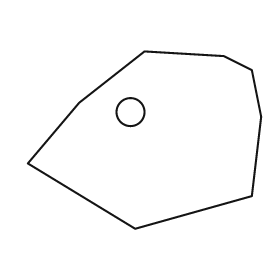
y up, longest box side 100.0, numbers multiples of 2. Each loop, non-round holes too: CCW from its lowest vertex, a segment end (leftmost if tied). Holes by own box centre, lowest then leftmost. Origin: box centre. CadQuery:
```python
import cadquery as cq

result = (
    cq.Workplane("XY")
    .moveTo(-4.0, -38.0)
    .lineTo(46.0, -24.0)
    .lineTo(50.0, 10.0)
    .lineTo(46.0, 30.0)
    .lineTo(34.0, 36.0)
    .lineTo(0.0, 38.0)
    .lineTo(-28.0, 16.0)
    .lineTo(-50.0, -10.0)
    .close()
    .moveTo(-6.0, 12.0)
    .circle(6.0)
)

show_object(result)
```